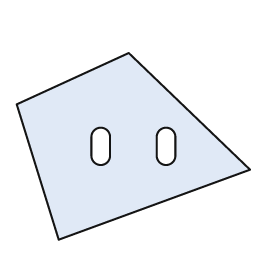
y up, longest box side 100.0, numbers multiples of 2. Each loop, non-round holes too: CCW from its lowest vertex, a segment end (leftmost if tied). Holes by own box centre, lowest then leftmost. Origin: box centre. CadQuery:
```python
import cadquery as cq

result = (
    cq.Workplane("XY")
    .moveTo(-32.0, -40.0)
    .lineTo(50.0, -10.0)
    .lineTo(-2.0, 40.0)
    .lineTo(-50.0, 18.0)
    .close()
    .moveTo(-18.0, -4.0)
    .threePointArc((-14.0, -8.0), (-10.0, -4.0))
    .lineTo(-10.0, 4.0)
    .threePointArc((-14.0, 8.0), (-18.0, 4.0))
    .close()
    .moveTo(10.0, -4.0)
    .threePointArc((14.0, -8.0), (18.0, -4.0))
    .lineTo(18.0, 4.0)
    .threePointArc((14.0, 8.0), (10.0, 4.0))
    .close()
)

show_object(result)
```